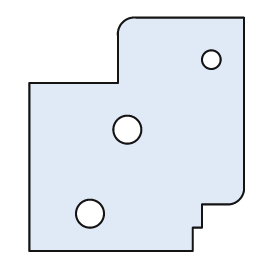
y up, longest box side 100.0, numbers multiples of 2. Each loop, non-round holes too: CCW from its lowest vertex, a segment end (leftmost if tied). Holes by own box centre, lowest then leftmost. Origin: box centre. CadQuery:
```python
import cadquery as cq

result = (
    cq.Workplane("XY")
    .moveTo(-46.0, -50.0)
    .lineTo(24.0, -50.0)
    .lineTo(24.0, -40.0)
    .lineTo(28.0, -40.0)
    .lineTo(28.0, -30.0)
    .lineTo(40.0, -30.0)
    .threePointArc((44.0, -28.0), (46.0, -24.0))
    .lineTo(46.0, 50.0)
    .lineTo(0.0, 50.0)
    .threePointArc((-6.0, 48.0), (-8.0, 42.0))
    .lineTo(-8.0, 22.0)
    .lineTo(-46.0, 22.0)
    .close()
    .moveTo(-20.0, -34.0)
    .circle(6.0)
    .moveTo(-4.0, 2.0)
    .circle(6.0)
    .moveTo(32.0, 32.0)
    .circle(4.0)
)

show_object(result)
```